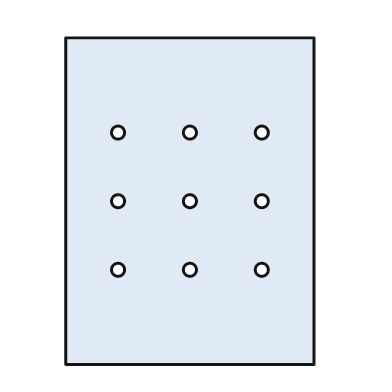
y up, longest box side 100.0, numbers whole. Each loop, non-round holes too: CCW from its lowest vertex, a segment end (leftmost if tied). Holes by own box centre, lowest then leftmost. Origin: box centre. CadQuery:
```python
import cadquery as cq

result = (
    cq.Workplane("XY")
    .moveTo(-38.0, -50.0)
    .lineTo(38.0, -50.0)
    .lineTo(38.0, 50.0)
    .lineTo(-38.0, 50.0)
    .close()
    .moveTo(-22.0, -21.0)
    .circle(2.0)
    .moveTo(0.0, -21.0)
    .circle(2.0)
    .moveTo(22.0, -21.0)
    .circle(2.0)
    .moveTo(-22.0, 0.0)
    .circle(2.0)
    .moveTo(0.0, 0.0)
    .circle(2.0)
    .moveTo(22.0, 0.0)
    .circle(2.0)
    .moveTo(-22.0, 21.0)
    .circle(2.0)
    .moveTo(0.0, 21.0)
    .circle(2.0)
    .moveTo(22.0, 21.0)
    .circle(2.0)
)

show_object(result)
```